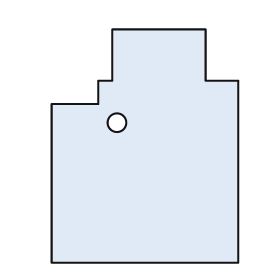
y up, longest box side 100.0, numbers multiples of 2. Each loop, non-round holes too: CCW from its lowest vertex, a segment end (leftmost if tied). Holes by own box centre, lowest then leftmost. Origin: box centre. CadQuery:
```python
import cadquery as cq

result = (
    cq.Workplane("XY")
    .moveTo(-40.0, -50.0)
    .lineTo(40.0, -50.0)
    .lineTo(40.0, 28.0)
    .lineTo(26.0, 28.0)
    .lineTo(26.0, 50.0)
    .lineTo(-14.0, 50.0)
    .lineTo(-14.0, 28.0)
    .lineTo(-20.0, 28.0)
    .lineTo(-20.0, 18.0)
    .lineTo(-40.0, 18.0)
    .close()
    .moveTo(-12.0, 10.0)
    .circle(4.0)
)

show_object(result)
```